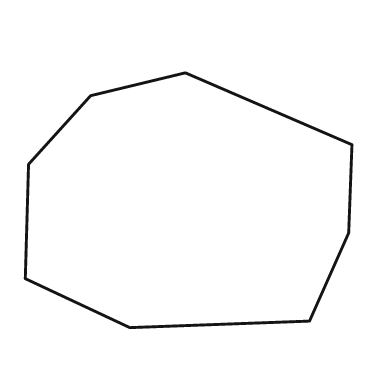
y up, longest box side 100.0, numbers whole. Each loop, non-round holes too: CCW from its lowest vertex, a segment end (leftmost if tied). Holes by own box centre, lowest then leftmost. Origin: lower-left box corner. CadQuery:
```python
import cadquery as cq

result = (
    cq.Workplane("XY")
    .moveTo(32.0, 0.0)
    .lineTo(87.0, 2.0)
    .lineTo(99.0, 29.0)
    .lineTo(100.0, 56.0)
    .lineTo(49.0, 78.0)
    .lineTo(20.0, 71.0)
    .lineTo(1.0, 50.0)
    .lineTo(0.0, 15.0)
    .close()
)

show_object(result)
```